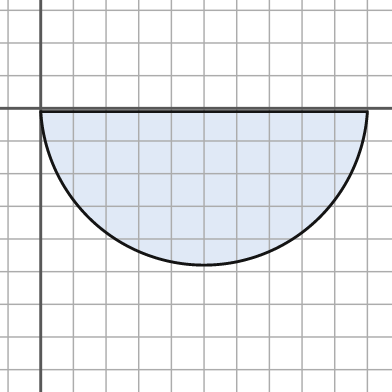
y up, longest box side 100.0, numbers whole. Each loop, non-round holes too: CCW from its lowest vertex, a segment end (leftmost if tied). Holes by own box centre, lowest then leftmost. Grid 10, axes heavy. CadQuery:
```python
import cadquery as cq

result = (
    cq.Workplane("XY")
    .moveTo(0.0, -1.0)
    .threePointArc((50.0, -48.0), (100.0, -1.0))
    .close()
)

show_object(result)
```